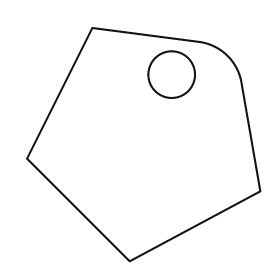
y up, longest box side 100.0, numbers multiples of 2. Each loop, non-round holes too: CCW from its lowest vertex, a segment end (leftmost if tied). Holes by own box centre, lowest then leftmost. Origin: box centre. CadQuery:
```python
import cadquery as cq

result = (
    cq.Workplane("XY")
    .moveTo(-6.0, -50.0)
    .lineTo(50.0, -20.0)
    .lineTo(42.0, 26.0)
    .threePointArc((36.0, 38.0), (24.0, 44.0))
    .lineTo(-22.0, 50.0)
    .lineTo(-50.0, -6.0)
    .close()
    .moveTo(12.0, 30.0)
    .circle(10.0)
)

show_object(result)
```